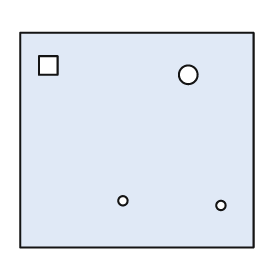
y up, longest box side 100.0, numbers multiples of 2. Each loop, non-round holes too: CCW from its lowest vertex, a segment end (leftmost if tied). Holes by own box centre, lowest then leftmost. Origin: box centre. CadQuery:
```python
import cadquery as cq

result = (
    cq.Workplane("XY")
    .moveTo(-50.0, -46.0)
    .lineTo(50.0, -46.0)
    .lineTo(50.0, 46.0)
    .lineTo(-50.0, 46.0)
    .close()
    .moveTo(36.0, -28.0)
    .circle(2.0)
    .moveTo(-6.0, -26.0)
    .circle(2.0)
    .moveTo(22.0, 28.0)
    .circle(4.0)
    .moveTo(-42.0, 28.0)
    .lineTo(-34.0, 28.0)
    .lineTo(-34.0, 36.0)
    .lineTo(-42.0, 36.0)
    .close()
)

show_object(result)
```